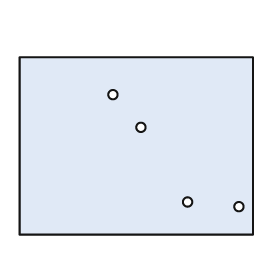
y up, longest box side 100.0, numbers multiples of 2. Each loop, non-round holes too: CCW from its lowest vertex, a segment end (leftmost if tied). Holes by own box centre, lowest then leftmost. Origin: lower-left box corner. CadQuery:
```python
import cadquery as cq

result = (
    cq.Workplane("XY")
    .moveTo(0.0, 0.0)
    .lineTo(100.0, 0.0)
    .lineTo(100.0, 76.0)
    .lineTo(0.0, 76.0)
    .close()
    .moveTo(94.0, 12.0)
    .circle(2.0)
    .moveTo(72.0, 14.0)
    .circle(2.0)
    .moveTo(52.0, 46.0)
    .circle(2.0)
    .moveTo(40.0, 60.0)
    .circle(2.0)
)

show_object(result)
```